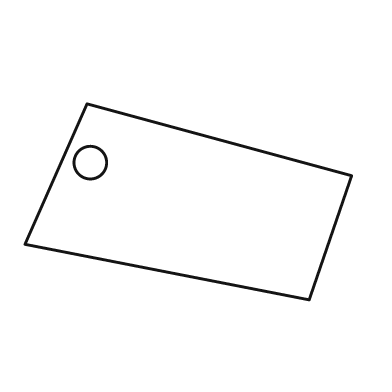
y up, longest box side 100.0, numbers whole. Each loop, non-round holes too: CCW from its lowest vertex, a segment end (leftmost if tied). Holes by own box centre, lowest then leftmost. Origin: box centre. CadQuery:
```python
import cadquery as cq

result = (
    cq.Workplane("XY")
    .moveTo(37.0, -30.0)
    .lineTo(50.0, 8.0)
    .lineTo(-31.0, 30.0)
    .lineTo(-50.0, -13.0)
    .close()
    .moveTo(-30.0, 12.0)
    .circle(5.0)
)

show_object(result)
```